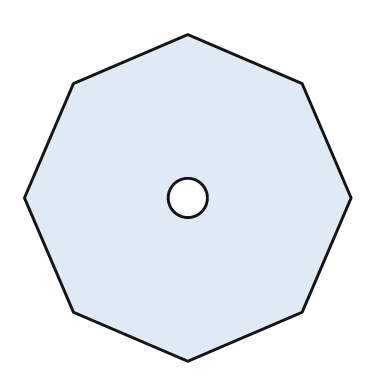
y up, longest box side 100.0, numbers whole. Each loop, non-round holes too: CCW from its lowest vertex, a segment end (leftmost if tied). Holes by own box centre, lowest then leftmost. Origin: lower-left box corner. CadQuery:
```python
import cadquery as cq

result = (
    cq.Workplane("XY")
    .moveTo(50.0, 0.0)
    .lineTo(85.0, 15.0)
    .lineTo(100.0, 50.0)
    .lineTo(85.0, 85.0)
    .lineTo(50.0, 100.0)
    .lineTo(15.0, 85.0)
    .lineTo(0.0, 50.0)
    .lineTo(15.0, 15.0)
    .close()
    .moveTo(50.0, 50.0)
    .circle(6.0)
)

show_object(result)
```